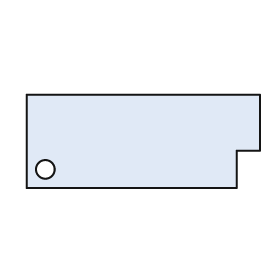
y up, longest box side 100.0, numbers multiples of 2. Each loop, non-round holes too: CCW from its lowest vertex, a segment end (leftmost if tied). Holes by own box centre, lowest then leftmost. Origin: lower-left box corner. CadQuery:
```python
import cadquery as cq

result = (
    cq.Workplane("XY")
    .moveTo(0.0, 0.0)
    .lineTo(90.0, 0.0)
    .lineTo(90.0, 16.0)
    .lineTo(100.0, 16.0)
    .lineTo(100.0, 40.0)
    .lineTo(0.0, 40.0)
    .close()
    .moveTo(8.0, 8.0)
    .circle(4.0)
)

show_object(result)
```